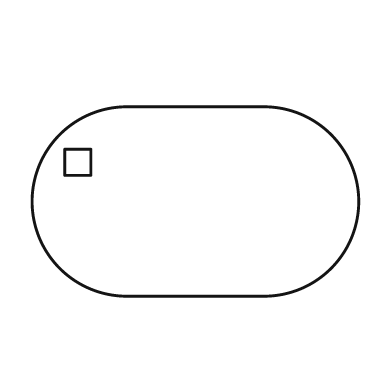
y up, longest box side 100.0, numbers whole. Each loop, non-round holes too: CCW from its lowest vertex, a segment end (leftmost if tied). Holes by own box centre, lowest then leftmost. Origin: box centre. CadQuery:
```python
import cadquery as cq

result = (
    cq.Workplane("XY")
    .moveTo(-21.0, -29.0)
    .lineTo(21.0, -29.0)
    .threePointArc((50.0, 0.0), (21.0, 29.0))
    .lineTo(-21.0, 29.0)
    .threePointArc((-50.0, 0.0), (-21.0, -29.0))
    .close()
    .moveTo(-40.0, 8.0)
    .lineTo(-32.0, 8.0)
    .lineTo(-32.0, 16.0)
    .lineTo(-40.0, 16.0)
    .close()
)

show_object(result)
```